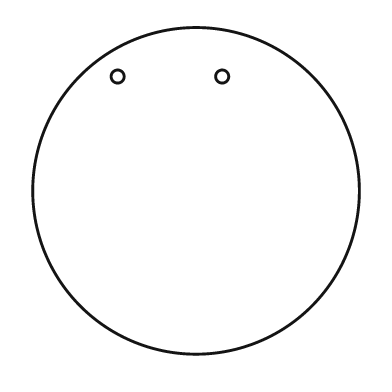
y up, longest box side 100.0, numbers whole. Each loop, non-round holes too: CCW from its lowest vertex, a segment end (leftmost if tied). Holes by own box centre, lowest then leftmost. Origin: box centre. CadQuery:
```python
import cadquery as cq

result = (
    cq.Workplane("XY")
    .moveTo(0.0, 0.0)
    .circle(50.0)
    .moveTo(-24.0, 35.0)
    .circle(2.0)
    .moveTo(8.0, 35.0)
    .circle(2.0)
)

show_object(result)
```